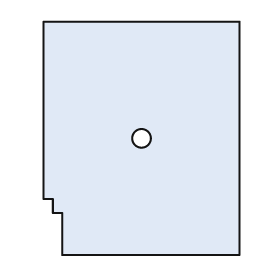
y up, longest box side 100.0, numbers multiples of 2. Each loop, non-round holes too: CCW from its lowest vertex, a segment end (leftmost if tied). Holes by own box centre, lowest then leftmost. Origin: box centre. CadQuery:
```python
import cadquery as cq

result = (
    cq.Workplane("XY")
    .moveTo(-34.0, -50.0)
    .lineTo(42.0, -50.0)
    .lineTo(42.0, 50.0)
    .lineTo(-42.0, 50.0)
    .lineTo(-42.0, -26.0)
    .lineTo(-38.0, -26.0)
    .lineTo(-38.0, -32.0)
    .lineTo(-34.0, -32.0)
    .close()
    .moveTo(0.0, 0.0)
    .circle(4.0)
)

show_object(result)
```